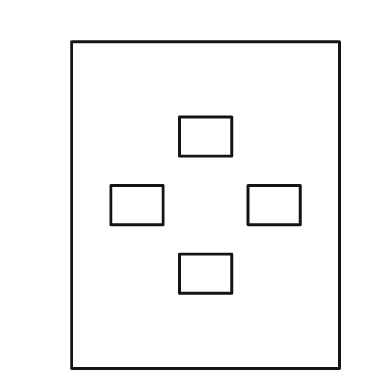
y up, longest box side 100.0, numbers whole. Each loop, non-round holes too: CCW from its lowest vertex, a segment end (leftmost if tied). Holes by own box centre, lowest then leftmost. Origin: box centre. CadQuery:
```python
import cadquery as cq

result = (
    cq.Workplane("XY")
    .moveTo(-41.0, -50.0)
    .lineTo(41.0, -50.0)
    .lineTo(41.0, 50.0)
    .lineTo(-41.0, 50.0)
    .close()
    .moveTo(-8.0, -27.0)
    .lineTo(8.0, -27.0)
    .lineTo(8.0, -15.0)
    .lineTo(-8.0, -15.0)
    .close()
    .moveTo(-29.0, -6.0)
    .lineTo(-13.0, -6.0)
    .lineTo(-13.0, 6.0)
    .lineTo(-29.0, 6.0)
    .close()
    .moveTo(13.0, -6.0)
    .lineTo(29.0, -6.0)
    .lineTo(29.0, 6.0)
    .lineTo(13.0, 6.0)
    .close()
    .moveTo(-8.0, 15.0)
    .lineTo(8.0, 15.0)
    .lineTo(8.0, 27.0)
    .lineTo(-8.0, 27.0)
    .close()
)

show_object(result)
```